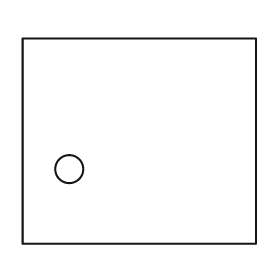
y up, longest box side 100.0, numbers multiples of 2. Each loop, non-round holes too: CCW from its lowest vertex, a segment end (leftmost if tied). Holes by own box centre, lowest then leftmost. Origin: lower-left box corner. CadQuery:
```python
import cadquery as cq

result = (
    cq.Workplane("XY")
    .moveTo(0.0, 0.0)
    .lineTo(100.0, 0.0)
    .lineTo(100.0, 88.0)
    .lineTo(0.0, 88.0)
    .close()
    .moveTo(20.0, 32.0)
    .circle(6.0)
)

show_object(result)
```